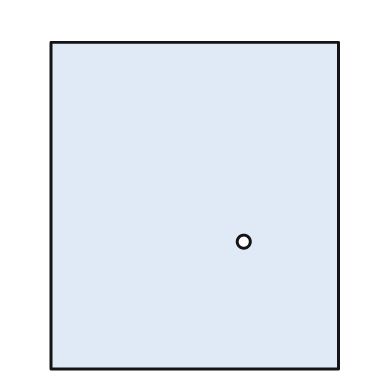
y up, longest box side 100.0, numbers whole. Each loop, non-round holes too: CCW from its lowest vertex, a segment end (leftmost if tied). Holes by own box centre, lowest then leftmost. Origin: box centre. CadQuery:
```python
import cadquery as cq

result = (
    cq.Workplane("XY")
    .moveTo(-44.0, -50.0)
    .lineTo(44.0, -50.0)
    .lineTo(44.0, 50.0)
    .lineTo(-44.0, 50.0)
    .close()
    .moveTo(15.0, -11.0)
    .circle(2.0)
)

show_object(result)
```